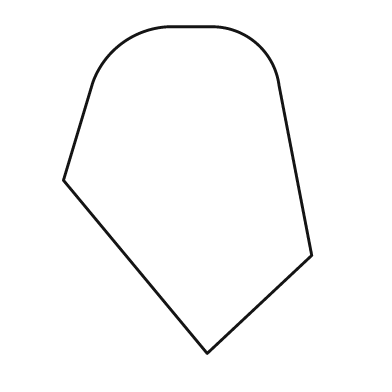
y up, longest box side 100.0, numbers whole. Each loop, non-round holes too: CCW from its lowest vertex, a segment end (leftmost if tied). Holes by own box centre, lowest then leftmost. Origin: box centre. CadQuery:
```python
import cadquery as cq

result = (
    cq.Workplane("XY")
    .moveTo(6.0, -50.0)
    .lineTo(38.0, -20.0)
    .lineTo(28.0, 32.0)
    .threePointArc((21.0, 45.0), (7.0, 50.0))
    .lineTo(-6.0, 50.0)
    .threePointArc((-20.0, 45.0), (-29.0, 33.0))
    .lineTo(-38.0, 3.0)
    .close()
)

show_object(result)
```